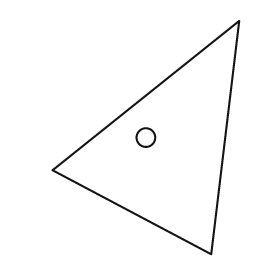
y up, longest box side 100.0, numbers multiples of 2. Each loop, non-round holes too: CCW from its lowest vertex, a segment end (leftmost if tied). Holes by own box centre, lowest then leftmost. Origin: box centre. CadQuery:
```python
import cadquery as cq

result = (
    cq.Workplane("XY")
    .moveTo(28.0, -50.0)
    .lineTo(40.0, 50.0)
    .lineTo(-40.0, -14.0)
    .close()
    .moveTo(0.0, 0.0)
    .circle(4.0)
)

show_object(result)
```